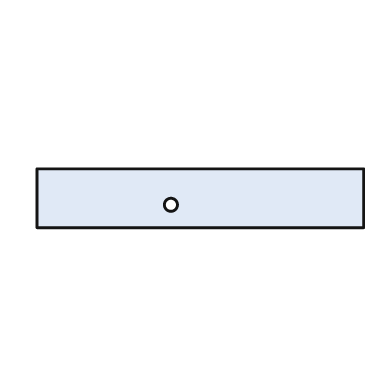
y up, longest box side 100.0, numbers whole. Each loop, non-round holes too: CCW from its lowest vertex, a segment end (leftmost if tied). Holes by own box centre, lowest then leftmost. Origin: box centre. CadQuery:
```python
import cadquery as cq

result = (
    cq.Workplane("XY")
    .moveTo(-50.0, -9.0)
    .lineTo(50.0, -9.0)
    .lineTo(50.0, 9.0)
    .lineTo(-50.0, 9.0)
    .close()
    .moveTo(-9.0, -2.0)
    .circle(2.0)
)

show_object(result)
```